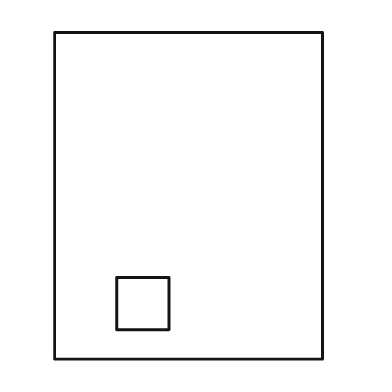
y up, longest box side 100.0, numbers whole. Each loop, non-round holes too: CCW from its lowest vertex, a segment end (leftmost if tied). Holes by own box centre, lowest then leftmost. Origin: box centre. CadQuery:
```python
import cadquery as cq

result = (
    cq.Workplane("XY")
    .moveTo(-41.0, -50.0)
    .lineTo(41.0, -50.0)
    .lineTo(41.0, 50.0)
    .lineTo(-41.0, 50.0)
    .close()
    .moveTo(-22.0, -41.0)
    .lineTo(-6.0, -41.0)
    .lineTo(-6.0, -25.0)
    .lineTo(-22.0, -25.0)
    .close()
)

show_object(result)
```